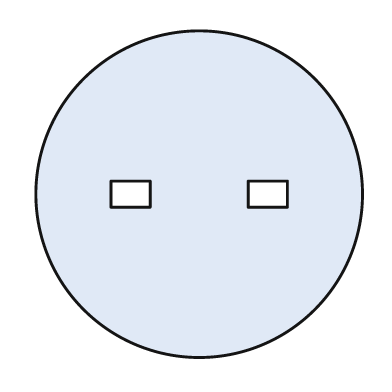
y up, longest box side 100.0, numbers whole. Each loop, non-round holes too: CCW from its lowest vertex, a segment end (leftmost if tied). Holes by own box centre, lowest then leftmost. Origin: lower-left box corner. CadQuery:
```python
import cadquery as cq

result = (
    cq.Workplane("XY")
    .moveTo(50.0, 50.0)
    .circle(50.0)
    .moveTo(23.0, 46.0)
    .lineTo(35.0, 46.0)
    .lineTo(35.0, 54.0)
    .lineTo(23.0, 54.0)
    .close()
    .moveTo(65.0, 46.0)
    .lineTo(77.0, 46.0)
    .lineTo(77.0, 54.0)
    .lineTo(65.0, 54.0)
    .close()
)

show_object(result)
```